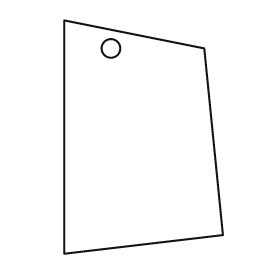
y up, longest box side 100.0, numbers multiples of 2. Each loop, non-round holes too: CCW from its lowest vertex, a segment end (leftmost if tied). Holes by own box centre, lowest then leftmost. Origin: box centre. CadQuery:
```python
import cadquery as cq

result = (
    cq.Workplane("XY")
    .moveTo(-34.0, -50.0)
    .lineTo(34.0, -42.0)
    .lineTo(26.0, 38.0)
    .lineTo(-34.0, 50.0)
    .close()
    .moveTo(-14.0, 38.0)
    .circle(4.0)
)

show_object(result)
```